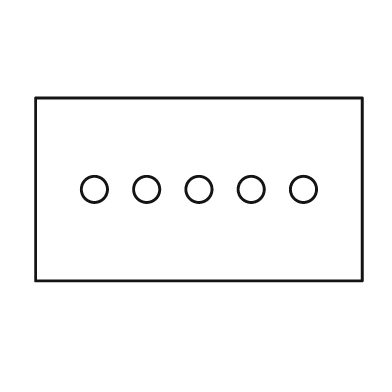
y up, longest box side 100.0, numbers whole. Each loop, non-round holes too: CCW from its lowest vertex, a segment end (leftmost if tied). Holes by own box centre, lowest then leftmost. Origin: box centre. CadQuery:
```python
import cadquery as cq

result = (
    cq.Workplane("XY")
    .moveTo(-50.0, -28.0)
    .lineTo(50.0, -28.0)
    .lineTo(50.0, 28.0)
    .lineTo(-50.0, 28.0)
    .close()
    .moveTo(-32.0, 0.0)
    .circle(4.0)
    .moveTo(-16.0, 0.0)
    .circle(4.0)
    .moveTo(0.0, 0.0)
    .circle(4.0)
    .moveTo(16.0, 0.0)
    .circle(4.0)
    .moveTo(32.0, 0.0)
    .circle(4.0)
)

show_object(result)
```